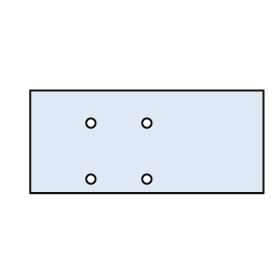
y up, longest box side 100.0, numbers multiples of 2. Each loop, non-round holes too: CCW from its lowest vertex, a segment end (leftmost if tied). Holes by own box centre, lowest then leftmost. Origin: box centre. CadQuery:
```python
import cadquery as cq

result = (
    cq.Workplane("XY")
    .moveTo(-50.0, -22.0)
    .lineTo(50.0, -22.0)
    .lineTo(50.0, 22.0)
    .lineTo(-50.0, 22.0)
    .close()
    .moveTo(-24.0, -16.0)
    .circle(2.0)
    .moveTo(0.0, -16.0)
    .circle(2.0)
    .moveTo(-24.0, 8.0)
    .circle(2.0)
    .moveTo(0.0, 8.0)
    .circle(2.0)
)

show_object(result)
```